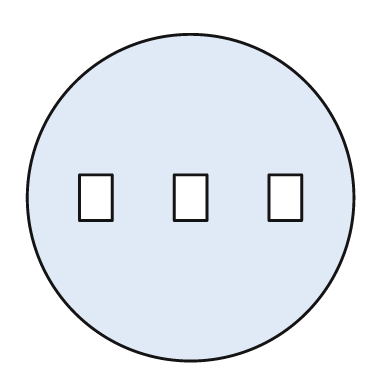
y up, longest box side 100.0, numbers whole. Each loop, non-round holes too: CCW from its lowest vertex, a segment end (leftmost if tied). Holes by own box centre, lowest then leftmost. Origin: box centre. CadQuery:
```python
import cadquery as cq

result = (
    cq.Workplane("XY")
    .moveTo(0.0, 0.0)
    .circle(50.0)
    .moveTo(-34.0, -7.0)
    .lineTo(-24.0, -7.0)
    .lineTo(-24.0, 7.0)
    .lineTo(-34.0, 7.0)
    .close()
    .moveTo(-5.0, -7.0)
    .lineTo(5.0, -7.0)
    .lineTo(5.0, 7.0)
    .lineTo(-5.0, 7.0)
    .close()
    .moveTo(24.0, -7.0)
    .lineTo(34.0, -7.0)
    .lineTo(34.0, 7.0)
    .lineTo(24.0, 7.0)
    .close()
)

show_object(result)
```